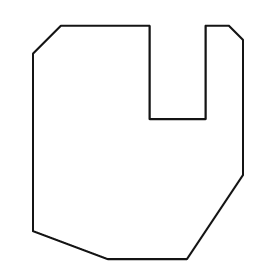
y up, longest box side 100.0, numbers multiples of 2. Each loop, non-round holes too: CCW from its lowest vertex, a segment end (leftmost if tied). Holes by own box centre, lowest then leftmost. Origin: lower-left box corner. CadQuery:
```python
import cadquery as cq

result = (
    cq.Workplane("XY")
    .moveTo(32.0, 0.0)
    .lineTo(66.0, 0.0)
    .lineTo(90.0, 36.0)
    .lineTo(90.0, 94.0)
    .lineTo(84.0, 100.0)
    .lineTo(74.0, 100.0)
    .lineTo(74.0, 60.0)
    .lineTo(50.0, 60.0)
    .lineTo(50.0, 100.0)
    .lineTo(12.0, 100.0)
    .lineTo(0.0, 88.0)
    .lineTo(0.0, 12.0)
    .close()
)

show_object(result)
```